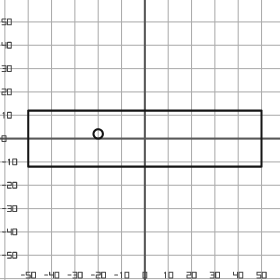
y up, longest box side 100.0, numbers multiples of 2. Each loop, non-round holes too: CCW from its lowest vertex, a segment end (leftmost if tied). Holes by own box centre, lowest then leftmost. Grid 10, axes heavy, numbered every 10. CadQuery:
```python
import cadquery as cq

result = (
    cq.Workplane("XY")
    .moveTo(-50.0, -12.0)
    .lineTo(50.0, -12.0)
    .lineTo(50.0, 12.0)
    .lineTo(-50.0, 12.0)
    .close()
    .moveTo(-20.0, 2.0)
    .circle(2.0)
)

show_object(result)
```